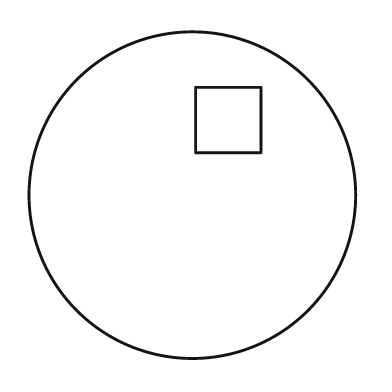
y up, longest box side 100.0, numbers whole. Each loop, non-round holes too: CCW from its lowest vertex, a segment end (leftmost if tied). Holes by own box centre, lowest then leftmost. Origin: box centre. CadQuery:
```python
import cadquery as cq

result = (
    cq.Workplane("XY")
    .moveTo(0.0, 0.0)
    .circle(50.0)
    .moveTo(1.0, 13.0)
    .lineTo(21.0, 13.0)
    .lineTo(21.0, 33.0)
    .lineTo(1.0, 33.0)
    .close()
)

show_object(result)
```